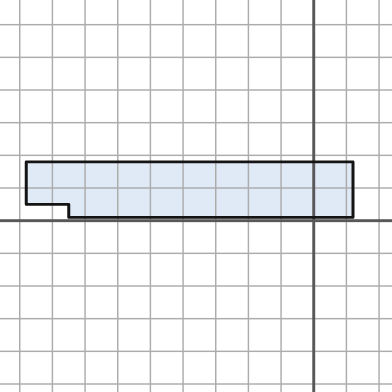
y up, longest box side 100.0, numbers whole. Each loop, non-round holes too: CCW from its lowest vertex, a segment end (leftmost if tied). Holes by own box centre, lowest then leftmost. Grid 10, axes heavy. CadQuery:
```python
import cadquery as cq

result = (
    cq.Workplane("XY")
    .moveTo(-75.0, 1.0)
    .lineTo(12.0, 1.0)
    .lineTo(12.0, 18.0)
    .lineTo(-88.0, 18.0)
    .lineTo(-88.0, 5.0)
    .lineTo(-75.0, 5.0)
    .close()
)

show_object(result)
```